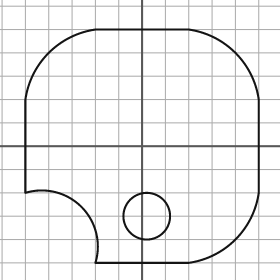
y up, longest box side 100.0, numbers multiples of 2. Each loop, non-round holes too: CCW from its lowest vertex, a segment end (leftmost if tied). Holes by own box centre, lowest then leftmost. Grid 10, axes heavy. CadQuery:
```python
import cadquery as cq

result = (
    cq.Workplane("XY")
    .moveTo(-20.0, -50.0)
    .lineTo(20.0, -50.0)
    .threePointArc((40.0, -40.0), (50.0, -20.0))
    .lineTo(50.0, 20.0)
    .threePointArc((40.0, 40.0), (20.0, 50.0))
    .lineTo(-20.0, 50.0)
    .threePointArc((-40.0, 40.0), (-50.0, 20.0))
    .lineTo(-50.0, -20.0)
    .threePointArc((-26.0, -26.0), (-20.0, -50.0))
    .close()
    .moveTo(2.0, -30.0)
    .circle(10.0)
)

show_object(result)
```